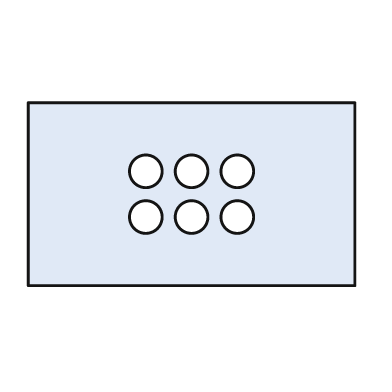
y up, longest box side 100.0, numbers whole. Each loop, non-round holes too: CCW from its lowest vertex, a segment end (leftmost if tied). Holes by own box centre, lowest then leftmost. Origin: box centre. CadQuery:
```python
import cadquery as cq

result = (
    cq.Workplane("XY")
    .moveTo(-50.0, -28.0)
    .lineTo(50.0, -28.0)
    .lineTo(50.0, 28.0)
    .lineTo(-50.0, 28.0)
    .close()
    .moveTo(-14.0, -7.0)
    .circle(5.0)
    .moveTo(0.0, -7.0)
    .circle(5.0)
    .moveTo(14.0, -7.0)
    .circle(5.0)
    .moveTo(-14.0, 7.0)
    .circle(5.0)
    .moveTo(0.0, 7.0)
    .circle(5.0)
    .moveTo(14.0, 7.0)
    .circle(5.0)
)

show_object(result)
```